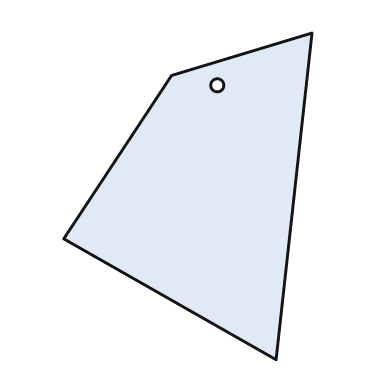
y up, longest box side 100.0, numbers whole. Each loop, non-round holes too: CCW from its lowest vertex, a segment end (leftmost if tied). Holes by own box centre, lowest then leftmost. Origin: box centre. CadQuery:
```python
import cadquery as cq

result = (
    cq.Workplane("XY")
    .moveTo(27.0, -50.0)
    .lineTo(38.0, 50.0)
    .lineTo(-5.0, 37.0)
    .lineTo(-38.0, -13.0)
    .close()
    .moveTo(9.0, 34.0)
    .circle(2.0)
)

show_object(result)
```